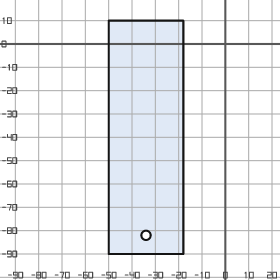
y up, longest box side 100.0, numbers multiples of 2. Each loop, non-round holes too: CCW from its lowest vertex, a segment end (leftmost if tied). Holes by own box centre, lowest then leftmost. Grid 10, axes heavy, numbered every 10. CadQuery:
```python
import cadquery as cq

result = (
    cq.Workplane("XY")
    .moveTo(-50.0, -90.0)
    .lineTo(-18.0, -90.0)
    .lineTo(-18.0, 10.0)
    .lineTo(-50.0, 10.0)
    .close()
    .moveTo(-34.0, -82.0)
    .circle(2.0)
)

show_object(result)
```